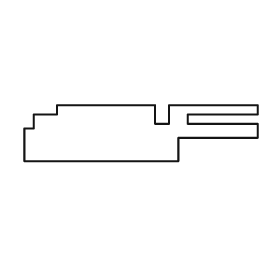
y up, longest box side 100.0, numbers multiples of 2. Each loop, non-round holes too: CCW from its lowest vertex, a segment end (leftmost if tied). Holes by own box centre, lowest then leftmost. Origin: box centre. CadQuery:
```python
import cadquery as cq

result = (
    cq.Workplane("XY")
    .moveTo(-50.0, -12.0)
    .lineTo(16.0, -12.0)
    .lineTo(16.0, -2.0)
    .lineTo(50.0, -2.0)
    .lineTo(50.0, 4.0)
    .lineTo(20.0, 4.0)
    .lineTo(20.0, 8.0)
    .lineTo(50.0, 8.0)
    .lineTo(50.0, 12.0)
    .lineTo(12.0, 12.0)
    .lineTo(12.0, 4.0)
    .lineTo(6.0, 4.0)
    .lineTo(6.0, 12.0)
    .lineTo(-36.0, 12.0)
    .lineTo(-36.0, 8.0)
    .lineTo(-46.0, 8.0)
    .lineTo(-46.0, 2.0)
    .lineTo(-50.0, 2.0)
    .close()
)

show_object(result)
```